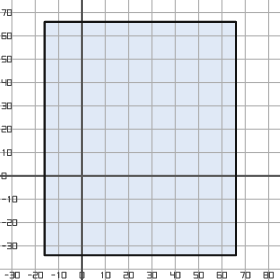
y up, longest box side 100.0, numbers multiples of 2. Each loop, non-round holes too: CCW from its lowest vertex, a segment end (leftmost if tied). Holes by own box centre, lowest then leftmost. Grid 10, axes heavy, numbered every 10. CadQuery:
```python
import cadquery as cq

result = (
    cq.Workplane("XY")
    .moveTo(-16.0, -34.0)
    .lineTo(66.0, -34.0)
    .lineTo(66.0, 66.0)
    .lineTo(-16.0, 66.0)
    .close()
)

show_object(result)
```